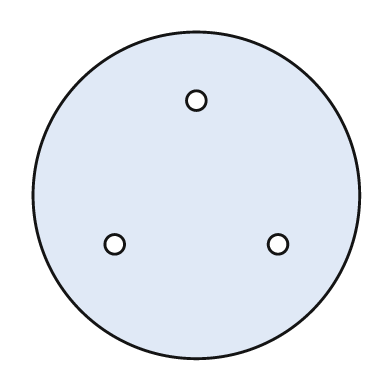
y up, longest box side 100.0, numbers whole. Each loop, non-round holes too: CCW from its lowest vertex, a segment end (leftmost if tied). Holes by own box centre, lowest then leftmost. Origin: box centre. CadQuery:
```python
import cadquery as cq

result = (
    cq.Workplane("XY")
    .moveTo(0.0, 0.0)
    .circle(50.0)
    .moveTo(-25.0, -15.0)
    .circle(3.0)
    .moveTo(25.0, -15.0)
    .circle(3.0)
    .moveTo(0.0, 29.0)
    .circle(3.0)
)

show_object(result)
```